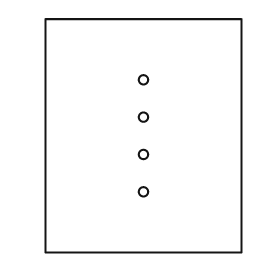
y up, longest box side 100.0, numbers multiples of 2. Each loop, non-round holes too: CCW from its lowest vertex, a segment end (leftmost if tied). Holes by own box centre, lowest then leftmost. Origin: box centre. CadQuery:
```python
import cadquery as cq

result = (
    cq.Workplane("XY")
    .moveTo(-42.0, -50.0)
    .lineTo(42.0, -50.0)
    .lineTo(42.0, 50.0)
    .lineTo(-42.0, 50.0)
    .close()
    .moveTo(0.0, -24.0)
    .circle(2.0)
    .moveTo(0.0, -8.0)
    .circle(2.0)
    .moveTo(0.0, 8.0)
    .circle(2.0)
    .moveTo(0.0, 24.0)
    .circle(2.0)
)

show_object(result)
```